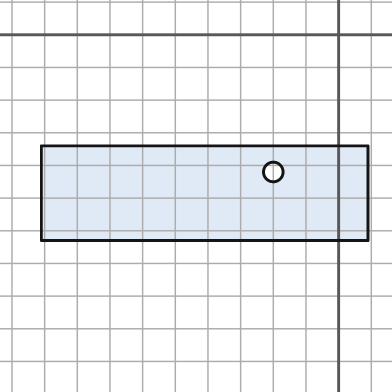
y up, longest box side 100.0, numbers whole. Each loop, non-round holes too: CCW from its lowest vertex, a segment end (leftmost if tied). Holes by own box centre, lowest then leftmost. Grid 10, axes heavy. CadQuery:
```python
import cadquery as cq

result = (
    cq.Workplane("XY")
    .moveTo(-91.0, -63.0)
    .lineTo(9.0, -63.0)
    .lineTo(9.0, -34.0)
    .lineTo(-91.0, -34.0)
    .close()
    .moveTo(-20.0, -42.0)
    .circle(3.0)
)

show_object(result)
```